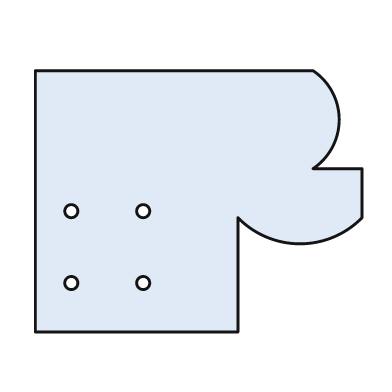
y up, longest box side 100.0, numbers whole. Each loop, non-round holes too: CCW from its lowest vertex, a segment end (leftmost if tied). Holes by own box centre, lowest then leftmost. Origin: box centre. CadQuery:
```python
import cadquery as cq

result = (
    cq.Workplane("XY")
    .moveTo(-50.0, -40.0)
    .lineTo(12.0, -40.0)
    .lineTo(12.0, -5.0)
    .threePointArc((31.0, -13.0), (50.0, -5.0))
    .lineTo(50.0, 10.0)
    .lineTo(35.0, 10.0)
    .threePointArc((43.0, 25.0), (35.0, 40.0))
    .lineTo(-50.0, 40.0)
    .close()
    .moveTo(-39.0, -25.0)
    .circle(2.0)
    .moveTo(-17.0, -25.0)
    .circle(2.0)
    .moveTo(-39.0, -3.0)
    .circle(2.0)
    .moveTo(-17.0, -3.0)
    .circle(2.0)
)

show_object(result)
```